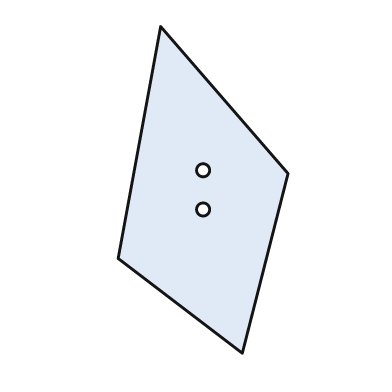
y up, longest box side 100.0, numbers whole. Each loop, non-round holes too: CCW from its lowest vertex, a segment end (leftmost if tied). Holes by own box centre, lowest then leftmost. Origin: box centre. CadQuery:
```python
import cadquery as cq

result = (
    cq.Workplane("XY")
    .moveTo(12.0, -50.0)
    .lineTo(26.0, 5.0)
    .lineTo(-13.0, 50.0)
    .lineTo(-26.0, -21.0)
    .close()
    .moveTo(0.0, -6.0)
    .circle(2.0)
    .moveTo(0.0, 6.0)
    .circle(2.0)
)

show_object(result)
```